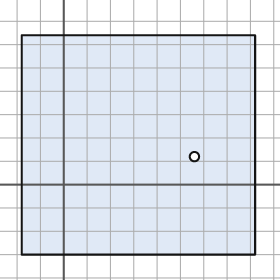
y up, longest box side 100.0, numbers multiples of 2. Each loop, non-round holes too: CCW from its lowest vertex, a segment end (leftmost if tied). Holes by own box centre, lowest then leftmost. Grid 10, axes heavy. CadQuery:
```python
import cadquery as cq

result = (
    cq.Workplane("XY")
    .moveTo(-18.0, -30.0)
    .lineTo(82.0, -30.0)
    .lineTo(82.0, 64.0)
    .lineTo(-18.0, 64.0)
    .close()
    .moveTo(56.0, 12.0)
    .circle(2.0)
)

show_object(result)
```